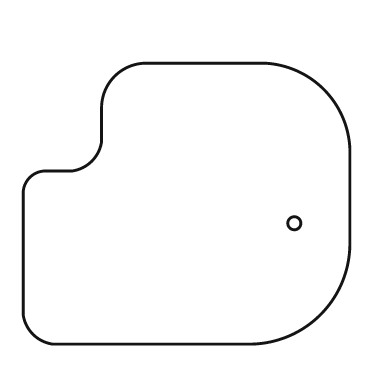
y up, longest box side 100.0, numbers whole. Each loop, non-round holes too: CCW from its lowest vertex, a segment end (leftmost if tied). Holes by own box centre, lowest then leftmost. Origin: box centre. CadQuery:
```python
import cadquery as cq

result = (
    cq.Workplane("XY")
    .moveTo(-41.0, -43.0)
    .lineTo(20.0, -43.0)
    .threePointArc((41.0, -34.0), (50.0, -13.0))
    .lineTo(50.0, 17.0)
    .threePointArc((42.0, 35.0), (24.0, 43.0))
    .lineTo(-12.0, 43.0)
    .threePointArc((-22.0, 39.0), (-26.0, 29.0))
    .lineTo(-26.0, 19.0)
    .threePointArc((-29.0, 13.0), (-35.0, 10.0))
    .lineTo(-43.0, 10.0)
    .threePointArc((-48.0, 8.0), (-50.0, 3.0))
    .lineTo(-50.0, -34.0)
    .threePointArc((-47.0, -40.0), (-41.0, -43.0))
    .close()
    .moveTo(33.0, -6.0)
    .circle(2.0)
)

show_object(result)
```